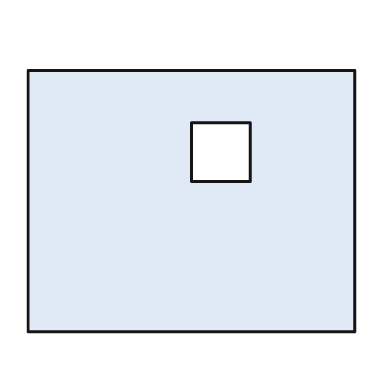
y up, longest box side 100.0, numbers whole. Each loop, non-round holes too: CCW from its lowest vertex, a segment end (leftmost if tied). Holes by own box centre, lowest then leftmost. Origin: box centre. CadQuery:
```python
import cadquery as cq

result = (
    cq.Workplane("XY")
    .moveTo(-50.0, -40.0)
    .lineTo(50.0, -40.0)
    .lineTo(50.0, 40.0)
    .lineTo(-50.0, 40.0)
    .close()
    .moveTo(0.0, 6.0)
    .lineTo(18.0, 6.0)
    .lineTo(18.0, 24.0)
    .lineTo(0.0, 24.0)
    .close()
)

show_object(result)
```